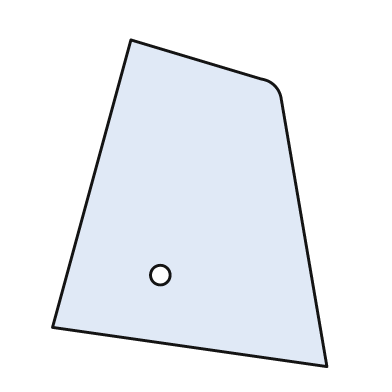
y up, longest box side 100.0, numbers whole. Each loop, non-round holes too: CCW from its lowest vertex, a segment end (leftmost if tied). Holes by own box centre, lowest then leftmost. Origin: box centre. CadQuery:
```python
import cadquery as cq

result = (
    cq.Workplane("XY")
    .moveTo(42.0, -50.0)
    .lineTo(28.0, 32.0)
    .threePointArc((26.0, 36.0), (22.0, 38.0))
    .lineTo(-18.0, 50.0)
    .lineTo(-42.0, -38.0)
    .close()
    .moveTo(-9.0, -22.0)
    .circle(3.0)
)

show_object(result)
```